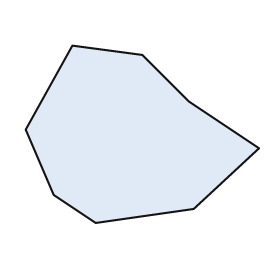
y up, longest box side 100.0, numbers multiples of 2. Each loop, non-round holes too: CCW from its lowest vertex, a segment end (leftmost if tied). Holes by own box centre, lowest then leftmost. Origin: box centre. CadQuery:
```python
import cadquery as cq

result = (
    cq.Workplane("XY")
    .moveTo(-20.0, -38.0)
    .lineTo(22.0, -32.0)
    .lineTo(50.0, -6.0)
    .lineTo(20.0, 14.0)
    .lineTo(0.0, 34.0)
    .lineTo(-30.0, 38.0)
    .lineTo(-50.0, 2.0)
    .lineTo(-38.0, -26.0)
    .close()
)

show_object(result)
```